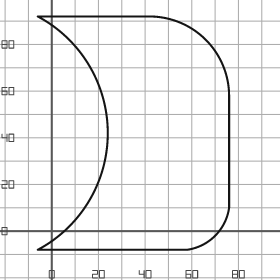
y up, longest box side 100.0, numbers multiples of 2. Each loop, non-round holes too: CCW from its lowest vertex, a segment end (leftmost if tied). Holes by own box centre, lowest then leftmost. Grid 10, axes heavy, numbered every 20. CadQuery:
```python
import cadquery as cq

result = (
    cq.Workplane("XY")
    .moveTo(-6.0, -8.0)
    .lineTo(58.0, -8.0)
    .threePointArc((70.0, -2.0), (76.0, 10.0))
    .lineTo(76.0, 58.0)
    .threePointArc((66.0, 82.0), (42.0, 92.0))
    .lineTo(-6.0, 92.0)
    .threePointArc((24.0, 42.0), (-6.0, -8.0))
    .close()
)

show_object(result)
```